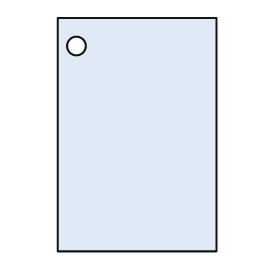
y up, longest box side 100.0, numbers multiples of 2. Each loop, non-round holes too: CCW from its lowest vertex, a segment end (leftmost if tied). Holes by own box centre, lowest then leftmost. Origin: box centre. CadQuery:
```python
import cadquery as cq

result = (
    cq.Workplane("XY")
    .moveTo(-34.0, -50.0)
    .lineTo(34.0, -50.0)
    .lineTo(34.0, 50.0)
    .lineTo(-34.0, 50.0)
    .close()
    .moveTo(-26.0, 38.0)
    .circle(4.0)
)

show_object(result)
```